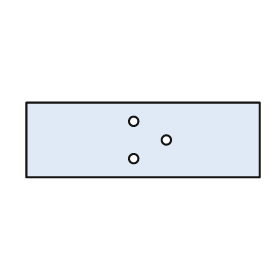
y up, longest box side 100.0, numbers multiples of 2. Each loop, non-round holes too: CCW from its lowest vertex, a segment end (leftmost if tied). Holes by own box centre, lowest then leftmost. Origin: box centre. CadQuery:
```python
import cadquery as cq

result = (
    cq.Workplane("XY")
    .moveTo(-50.0, -16.0)
    .lineTo(50.0, -16.0)
    .lineTo(50.0, 16.0)
    .lineTo(-50.0, 16.0)
    .close()
    .moveTo(-4.0, -8.0)
    .circle(2.0)
    .moveTo(10.0, 0.0)
    .circle(2.0)
    .moveTo(-4.0, 8.0)
    .circle(2.0)
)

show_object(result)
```